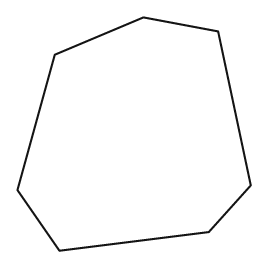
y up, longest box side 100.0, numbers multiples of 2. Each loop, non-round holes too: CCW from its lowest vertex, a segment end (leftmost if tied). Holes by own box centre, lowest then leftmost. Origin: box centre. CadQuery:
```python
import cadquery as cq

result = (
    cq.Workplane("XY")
    .moveTo(-32.0, -50.0)
    .lineTo(32.0, -42.0)
    .lineTo(50.0, -22.0)
    .lineTo(36.0, 44.0)
    .lineTo(4.0, 50.0)
    .lineTo(-34.0, 34.0)
    .lineTo(-50.0, -24.0)
    .close()
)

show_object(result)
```